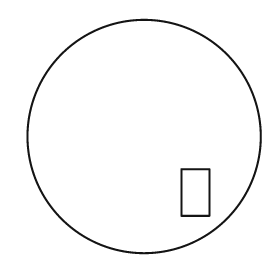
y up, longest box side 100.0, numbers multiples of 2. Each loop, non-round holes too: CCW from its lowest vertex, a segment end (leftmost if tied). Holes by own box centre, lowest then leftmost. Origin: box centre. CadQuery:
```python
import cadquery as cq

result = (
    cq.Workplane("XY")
    .moveTo(0.0, 0.0)
    .circle(50.0)
    .moveTo(16.0, -34.0)
    .lineTo(28.0, -34.0)
    .lineTo(28.0, -14.0)
    .lineTo(16.0, -14.0)
    .close()
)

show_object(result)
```